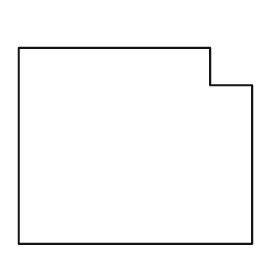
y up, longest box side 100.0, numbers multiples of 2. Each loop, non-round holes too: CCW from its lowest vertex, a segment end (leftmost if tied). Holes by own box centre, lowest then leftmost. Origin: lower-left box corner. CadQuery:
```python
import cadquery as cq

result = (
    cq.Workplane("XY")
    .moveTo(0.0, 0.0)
    .lineTo(100.0, 0.0)
    .lineTo(100.0, 68.0)
    .lineTo(82.0, 68.0)
    .lineTo(82.0, 84.0)
    .lineTo(0.0, 84.0)
    .close()
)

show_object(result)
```